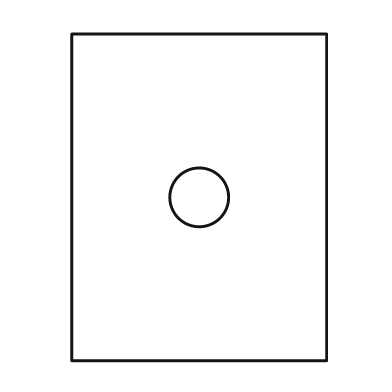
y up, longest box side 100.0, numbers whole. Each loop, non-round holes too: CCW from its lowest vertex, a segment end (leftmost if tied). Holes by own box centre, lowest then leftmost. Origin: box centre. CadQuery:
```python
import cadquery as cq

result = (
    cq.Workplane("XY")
    .moveTo(-39.0, -50.0)
    .lineTo(39.0, -50.0)
    .lineTo(39.0, 50.0)
    .lineTo(-39.0, 50.0)
    .close()
    .moveTo(0.0, 0.0)
    .circle(9.0)
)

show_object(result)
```